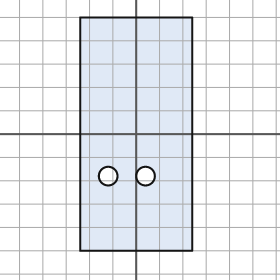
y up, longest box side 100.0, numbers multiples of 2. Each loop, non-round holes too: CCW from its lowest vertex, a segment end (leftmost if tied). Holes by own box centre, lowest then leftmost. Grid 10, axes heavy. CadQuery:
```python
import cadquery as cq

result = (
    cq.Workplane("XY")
    .moveTo(-24.0, -50.0)
    .lineTo(24.0, -50.0)
    .lineTo(24.0, 50.0)
    .lineTo(-24.0, 50.0)
    .close()
    .moveTo(-12.0, -18.0)
    .circle(4.0)
    .moveTo(4.0, -18.0)
    .circle(4.0)
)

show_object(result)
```